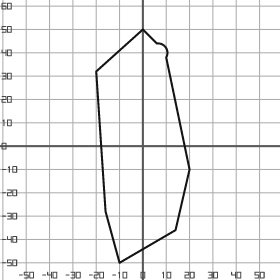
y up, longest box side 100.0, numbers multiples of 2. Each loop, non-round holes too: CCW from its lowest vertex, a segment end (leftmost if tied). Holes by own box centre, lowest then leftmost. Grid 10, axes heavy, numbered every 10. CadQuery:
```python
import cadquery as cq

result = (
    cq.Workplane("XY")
    .moveTo(-10.0, -50.0)
    .lineTo(14.0, -36.0)
    .lineTo(20.0, -10.0)
    .lineTo(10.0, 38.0)
    .threePointArc((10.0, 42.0), (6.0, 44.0))
    .lineTo(0.0, 50.0)
    .lineTo(-20.0, 32.0)
    .lineTo(-16.0, -28.0)
    .close()
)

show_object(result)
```